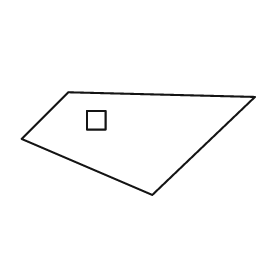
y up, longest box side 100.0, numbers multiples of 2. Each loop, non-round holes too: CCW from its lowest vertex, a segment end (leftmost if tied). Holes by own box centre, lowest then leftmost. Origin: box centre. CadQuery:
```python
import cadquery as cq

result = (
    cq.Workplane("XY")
    .moveTo(6.0, -22.0)
    .lineTo(50.0, 20.0)
    .lineTo(-30.0, 22.0)
    .lineTo(-50.0, 2.0)
    .close()
    .moveTo(-22.0, 6.0)
    .lineTo(-14.0, 6.0)
    .lineTo(-14.0, 14.0)
    .lineTo(-22.0, 14.0)
    .close()
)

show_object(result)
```